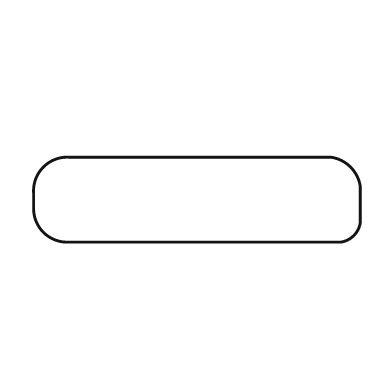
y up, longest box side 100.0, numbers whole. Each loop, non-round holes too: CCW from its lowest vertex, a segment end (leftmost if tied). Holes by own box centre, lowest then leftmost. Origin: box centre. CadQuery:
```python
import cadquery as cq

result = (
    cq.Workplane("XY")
    .moveTo(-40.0, -13.0)
    .lineTo(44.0, -13.0)
    .threePointArc((48.0, -11.0), (50.0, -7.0))
    .lineTo(50.0, 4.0)
    .threePointArc((47.0, 10.0), (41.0, 13.0))
    .lineTo(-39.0, 13.0)
    .threePointArc((-47.0, 10.0), (-50.0, 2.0))
    .lineTo(-50.0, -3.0)
    .threePointArc((-47.0, -10.0), (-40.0, -13.0))
    .close()
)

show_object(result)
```